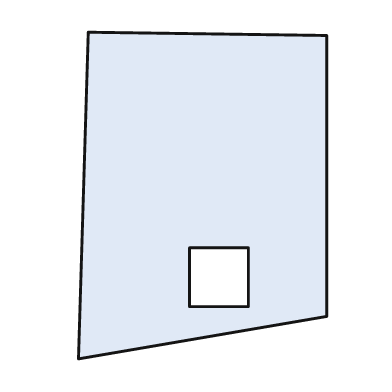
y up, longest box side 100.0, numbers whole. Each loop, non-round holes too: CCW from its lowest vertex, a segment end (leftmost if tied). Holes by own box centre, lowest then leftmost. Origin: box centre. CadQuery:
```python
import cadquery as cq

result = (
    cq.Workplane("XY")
    .moveTo(-38.0, -50.0)
    .lineTo(38.0, -37.0)
    .lineTo(38.0, 49.0)
    .lineTo(-35.0, 50.0)
    .close()
    .moveTo(-4.0, -34.0)
    .lineTo(14.0, -34.0)
    .lineTo(14.0, -16.0)
    .lineTo(-4.0, -16.0)
    .close()
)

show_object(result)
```